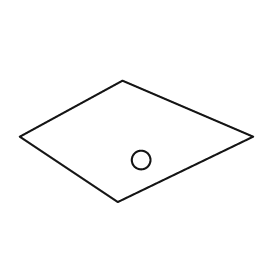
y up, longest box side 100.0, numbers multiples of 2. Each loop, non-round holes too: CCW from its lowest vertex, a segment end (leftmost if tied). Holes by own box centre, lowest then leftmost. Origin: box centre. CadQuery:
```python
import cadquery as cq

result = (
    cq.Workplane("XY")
    .moveTo(-8.0, -26.0)
    .lineTo(50.0, 2.0)
    .lineTo(-6.0, 26.0)
    .lineTo(-50.0, 2.0)
    .close()
    .moveTo(2.0, -8.0)
    .circle(4.0)
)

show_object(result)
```